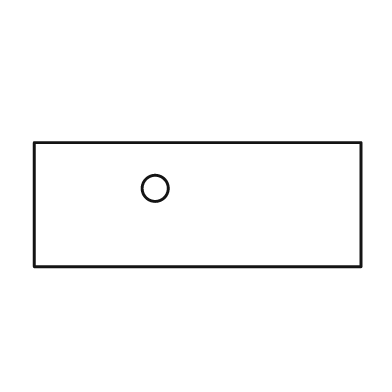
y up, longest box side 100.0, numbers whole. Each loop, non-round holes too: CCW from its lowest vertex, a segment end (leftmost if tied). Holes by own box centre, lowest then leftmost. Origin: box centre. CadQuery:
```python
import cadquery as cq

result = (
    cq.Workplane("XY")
    .moveTo(-50.0, -19.0)
    .lineTo(50.0, -19.0)
    .lineTo(50.0, 19.0)
    .lineTo(-50.0, 19.0)
    .close()
    .moveTo(-13.0, 5.0)
    .circle(4.0)
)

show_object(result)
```